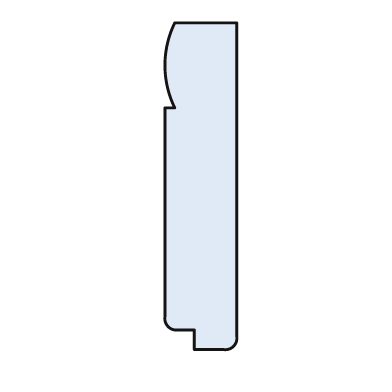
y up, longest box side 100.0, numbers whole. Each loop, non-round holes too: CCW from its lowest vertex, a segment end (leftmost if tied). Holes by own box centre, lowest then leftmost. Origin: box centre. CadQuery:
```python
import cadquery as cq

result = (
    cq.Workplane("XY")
    .moveTo(-2.0, -50.0)
    .lineTo(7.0, -50.0)
    .threePointArc((10.0, -49.0), (11.0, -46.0))
    .lineTo(11.0, 50.0)
    .lineTo(-8.0, 50.0)
    .threePointArc((-11.0, 37.0), (-8.0, 24.0))
    .lineTo(-11.0, 24.0)
    .lineTo(-11.0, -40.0)
    .threePointArc((-10.0, -43.0), (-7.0, -44.0))
    .lineTo(-2.0, -44.0)
    .close()
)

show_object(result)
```